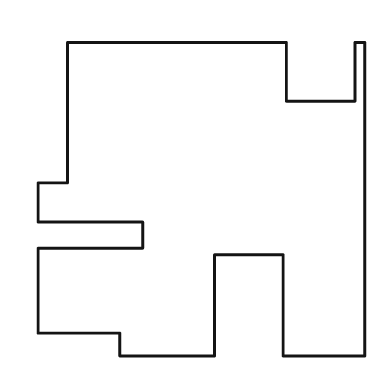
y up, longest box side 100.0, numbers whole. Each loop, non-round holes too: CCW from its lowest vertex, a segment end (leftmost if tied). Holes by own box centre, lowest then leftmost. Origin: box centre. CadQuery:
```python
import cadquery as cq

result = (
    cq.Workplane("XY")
    .moveTo(-25.0, -48.0)
    .lineTo(4.0, -48.0)
    .lineTo(4.0, -17.0)
    .lineTo(25.0, -17.0)
    .lineTo(25.0, -48.0)
    .lineTo(50.0, -48.0)
    .lineTo(50.0, 48.0)
    .lineTo(47.0, 48.0)
    .lineTo(47.0, 30.0)
    .lineTo(26.0, 30.0)
    .lineTo(26.0, 48.0)
    .lineTo(-41.0, 48.0)
    .lineTo(-41.0, 5.0)
    .lineTo(-50.0, 5.0)
    .lineTo(-50.0, -7.0)
    .lineTo(-18.0, -7.0)
    .lineTo(-18.0, -15.0)
    .lineTo(-50.0, -15.0)
    .lineTo(-50.0, -41.0)
    .lineTo(-25.0, -41.0)
    .close()
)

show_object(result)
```